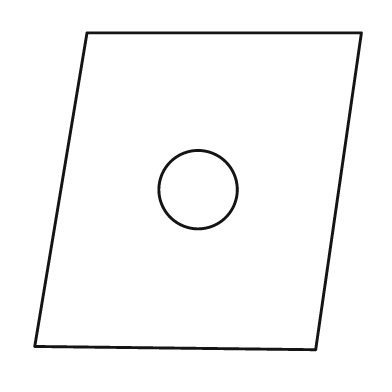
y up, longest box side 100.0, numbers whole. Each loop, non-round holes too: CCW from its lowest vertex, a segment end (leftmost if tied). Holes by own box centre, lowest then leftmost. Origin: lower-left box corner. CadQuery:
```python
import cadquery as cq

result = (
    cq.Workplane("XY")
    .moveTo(86.0, 0.0)
    .lineTo(100.0, 97.0)
    .lineTo(16.0, 97.0)
    .lineTo(0.0, 1.0)
    .close()
    .moveTo(50.0, 49.0)
    .circle(12.0)
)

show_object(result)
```